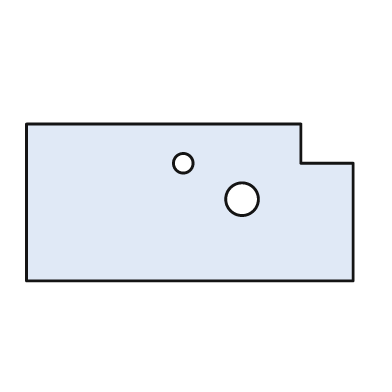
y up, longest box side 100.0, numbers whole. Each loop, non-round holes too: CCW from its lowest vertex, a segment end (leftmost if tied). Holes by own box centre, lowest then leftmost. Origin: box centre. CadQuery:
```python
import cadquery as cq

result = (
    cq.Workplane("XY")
    .moveTo(-50.0, -24.0)
    .lineTo(50.0, -24.0)
    .lineTo(50.0, 12.0)
    .lineTo(34.0, 12.0)
    .lineTo(34.0, 24.0)
    .lineTo(-50.0, 24.0)
    .close()
    .moveTo(16.0, 1.0)
    .circle(5.0)
    .moveTo(-2.0, 12.0)
    .circle(3.0)
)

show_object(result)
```